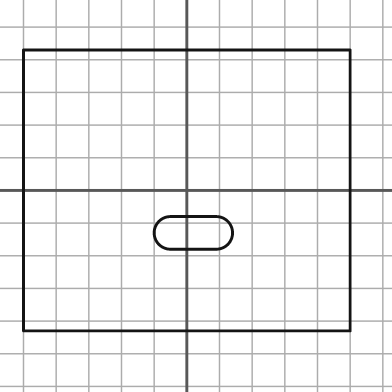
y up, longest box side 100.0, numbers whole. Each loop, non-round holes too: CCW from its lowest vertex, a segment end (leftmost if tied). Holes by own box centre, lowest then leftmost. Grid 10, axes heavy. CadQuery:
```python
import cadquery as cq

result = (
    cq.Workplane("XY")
    .moveTo(-50.0, -43.0)
    .lineTo(50.0, -43.0)
    .lineTo(50.0, 43.0)
    .lineTo(-50.0, 43.0)
    .close()
    .moveTo(-5.0, -18.0)
    .lineTo(9.0, -18.0)
    .threePointArc((14.0, -13.0), (9.0, -8.0))
    .lineTo(-5.0, -8.0)
    .threePointArc((-10.0, -13.0), (-5.0, -18.0))
    .close()
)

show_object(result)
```